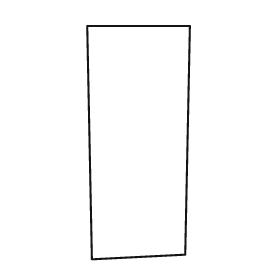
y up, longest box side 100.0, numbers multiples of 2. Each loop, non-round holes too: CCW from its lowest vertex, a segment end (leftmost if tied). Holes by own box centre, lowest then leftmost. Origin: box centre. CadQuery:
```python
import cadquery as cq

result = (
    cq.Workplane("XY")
    .moveTo(-20.0, -50.0)
    .lineTo(20.0, -48.0)
    .lineTo(22.0, 50.0)
    .lineTo(-22.0, 50.0)
    .close()
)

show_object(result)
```